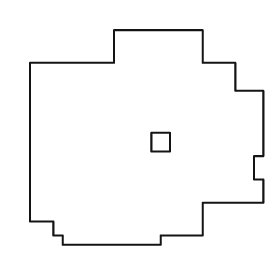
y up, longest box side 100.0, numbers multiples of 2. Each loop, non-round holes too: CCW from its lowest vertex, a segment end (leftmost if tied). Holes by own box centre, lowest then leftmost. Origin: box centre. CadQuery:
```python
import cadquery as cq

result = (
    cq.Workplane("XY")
    .moveTo(-36.0, -46.0)
    .lineTo(6.0, -46.0)
    .lineTo(6.0, -42.0)
    .lineTo(24.0, -42.0)
    .lineTo(24.0, -28.0)
    .lineTo(50.0, -28.0)
    .lineTo(50.0, -18.0)
    .lineTo(46.0, -18.0)
    .lineTo(46.0, -8.0)
    .lineTo(50.0, -8.0)
    .lineTo(50.0, 20.0)
    .lineTo(38.0, 20.0)
    .lineTo(38.0, 32.0)
    .lineTo(24.0, 32.0)
    .lineTo(24.0, 46.0)
    .lineTo(-14.0, 46.0)
    .lineTo(-14.0, 32.0)
    .lineTo(-50.0, 32.0)
    .lineTo(-50.0, -36.0)
    .lineTo(-40.0, -36.0)
    .lineTo(-40.0, -42.0)
    .lineTo(-36.0, -42.0)
    .close()
    .moveTo(2.0, -6.0)
    .lineTo(10.0, -6.0)
    .lineTo(10.0, 2.0)
    .lineTo(2.0, 2.0)
    .close()
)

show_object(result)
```